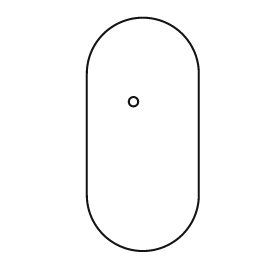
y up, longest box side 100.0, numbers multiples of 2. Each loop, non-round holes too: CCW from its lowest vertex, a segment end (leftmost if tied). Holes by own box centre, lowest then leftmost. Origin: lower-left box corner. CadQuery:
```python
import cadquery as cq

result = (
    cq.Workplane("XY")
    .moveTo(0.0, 24.0)
    .threePointArc((24.0, 0.0), (48.0, 24.0))
    .lineTo(48.0, 76.0)
    .threePointArc((24.0, 100.0), (0.0, 76.0))
    .close()
    .moveTo(20.0, 64.0)
    .circle(2.0)
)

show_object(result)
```